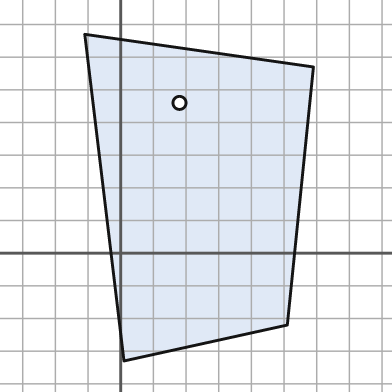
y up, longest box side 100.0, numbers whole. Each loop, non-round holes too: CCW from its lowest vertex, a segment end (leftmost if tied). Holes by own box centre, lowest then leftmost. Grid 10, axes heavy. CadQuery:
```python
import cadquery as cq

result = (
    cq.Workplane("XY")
    .moveTo(1.0, -33.0)
    .lineTo(51.0, -22.0)
    .lineTo(59.0, 57.0)
    .lineTo(-11.0, 67.0)
    .close()
    .moveTo(18.0, 46.0)
    .circle(2.0)
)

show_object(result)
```